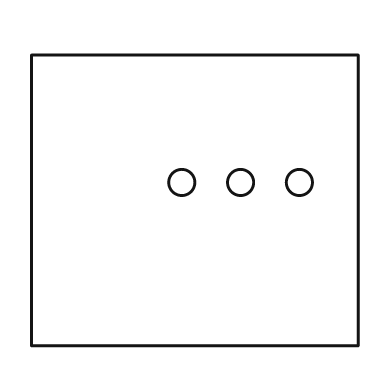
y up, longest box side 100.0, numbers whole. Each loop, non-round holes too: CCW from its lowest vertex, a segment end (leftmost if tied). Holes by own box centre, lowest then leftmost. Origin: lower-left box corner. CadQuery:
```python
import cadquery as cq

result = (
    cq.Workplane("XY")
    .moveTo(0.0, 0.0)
    .lineTo(100.0, 0.0)
    .lineTo(100.0, 89.0)
    .lineTo(0.0, 89.0)
    .close()
    .moveTo(46.0, 50.0)
    .circle(4.0)
    .moveTo(64.0, 50.0)
    .circle(4.0)
    .moveTo(82.0, 50.0)
    .circle(4.0)
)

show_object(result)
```